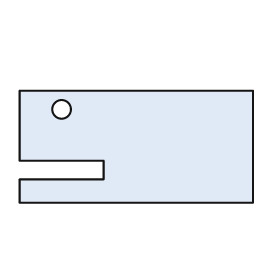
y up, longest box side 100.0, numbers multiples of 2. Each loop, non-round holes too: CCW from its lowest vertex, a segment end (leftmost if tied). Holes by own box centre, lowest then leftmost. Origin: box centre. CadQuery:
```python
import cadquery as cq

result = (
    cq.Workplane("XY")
    .moveTo(-50.0, -24.0)
    .lineTo(50.0, -24.0)
    .lineTo(50.0, 24.0)
    .lineTo(-50.0, 24.0)
    .lineTo(-50.0, -6.0)
    .lineTo(-14.0, -6.0)
    .lineTo(-14.0, -14.0)
    .lineTo(-50.0, -14.0)
    .close()
    .moveTo(-32.0, 16.0)
    .circle(4.0)
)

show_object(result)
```